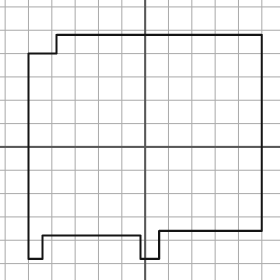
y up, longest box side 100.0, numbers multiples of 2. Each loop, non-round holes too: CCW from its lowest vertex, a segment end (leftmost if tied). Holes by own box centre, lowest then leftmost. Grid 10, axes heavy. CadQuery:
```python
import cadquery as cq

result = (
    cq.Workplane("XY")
    .moveTo(-50.0, -48.0)
    .lineTo(-44.0, -48.0)
    .lineTo(-44.0, -38.0)
    .lineTo(-2.0, -38.0)
    .lineTo(-2.0, -48.0)
    .lineTo(6.0, -48.0)
    .lineTo(6.0, -36.0)
    .lineTo(50.0, -36.0)
    .lineTo(50.0, 48.0)
    .lineTo(-38.0, 48.0)
    .lineTo(-38.0, 40.0)
    .lineTo(-50.0, 40.0)
    .close()
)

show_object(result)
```